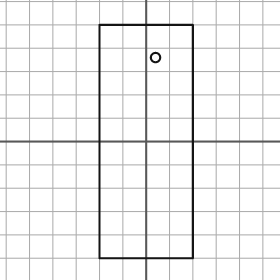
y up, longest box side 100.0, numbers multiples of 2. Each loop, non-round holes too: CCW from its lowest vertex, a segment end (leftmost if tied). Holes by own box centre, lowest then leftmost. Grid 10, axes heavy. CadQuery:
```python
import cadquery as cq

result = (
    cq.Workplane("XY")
    .moveTo(-20.0, -50.0)
    .lineTo(20.0, -50.0)
    .lineTo(20.0, 50.0)
    .lineTo(-20.0, 50.0)
    .close()
    .moveTo(4.0, 36.0)
    .circle(2.0)
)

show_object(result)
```